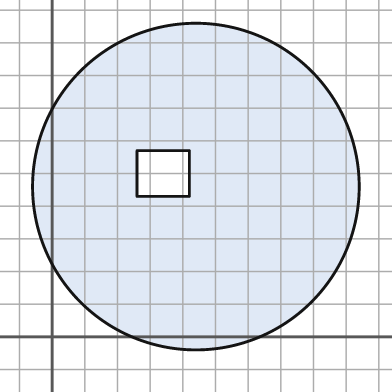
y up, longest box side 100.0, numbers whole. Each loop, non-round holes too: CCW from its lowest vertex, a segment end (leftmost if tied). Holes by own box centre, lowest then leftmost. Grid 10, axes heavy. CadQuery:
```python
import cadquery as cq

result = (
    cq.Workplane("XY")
    .moveTo(44.0, 46.0)
    .circle(50.0)
    .moveTo(26.0, 43.0)
    .lineTo(42.0, 43.0)
    .lineTo(42.0, 57.0)
    .lineTo(26.0, 57.0)
    .close()
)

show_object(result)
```